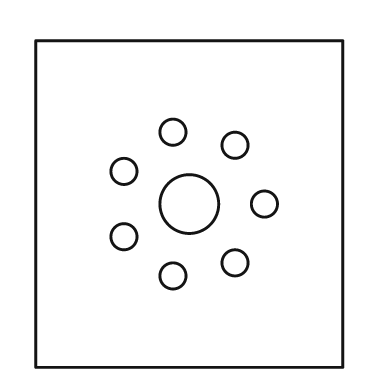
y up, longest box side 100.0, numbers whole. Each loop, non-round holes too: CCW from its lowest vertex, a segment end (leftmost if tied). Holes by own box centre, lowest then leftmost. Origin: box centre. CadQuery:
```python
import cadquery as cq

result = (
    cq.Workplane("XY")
    .moveTo(-47.0, -50.0)
    .lineTo(47.0, -50.0)
    .lineTo(47.0, 50.0)
    .lineTo(-47.0, 50.0)
    .close()
    .moveTo(-5.0, -22.0)
    .circle(4.0)
    .moveTo(14.0, -18.0)
    .circle(4.0)
    .moveTo(-20.0, -10.0)
    .circle(4.0)
    .moveTo(0.0, 0.0)
    .circle(9.0)
    .moveTo(23.0, 0.0)
    .circle(4.0)
    .moveTo(-20.0, 10.0)
    .circle(4.0)
    .moveTo(14.0, 18.0)
    .circle(4.0)
    .moveTo(-5.0, 22.0)
    .circle(4.0)
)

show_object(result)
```